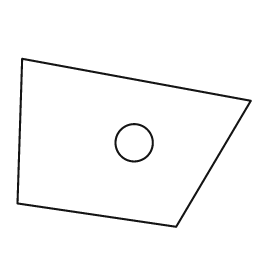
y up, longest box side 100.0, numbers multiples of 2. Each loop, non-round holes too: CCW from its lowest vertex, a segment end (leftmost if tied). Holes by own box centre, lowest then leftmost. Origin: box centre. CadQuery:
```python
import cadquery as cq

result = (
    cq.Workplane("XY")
    .moveTo(18.0, -36.0)
    .lineTo(50.0, 18.0)
    .lineTo(-48.0, 36.0)
    .lineTo(-50.0, -26.0)
    .close()
    .moveTo(0.0, 0.0)
    .circle(8.0)
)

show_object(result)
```